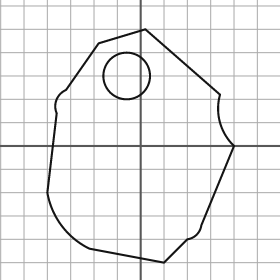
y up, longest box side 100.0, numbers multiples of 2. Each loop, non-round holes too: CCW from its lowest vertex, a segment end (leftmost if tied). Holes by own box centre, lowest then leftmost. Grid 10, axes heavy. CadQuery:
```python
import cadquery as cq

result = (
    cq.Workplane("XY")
    .moveTo(10.0, -50.0)
    .lineTo(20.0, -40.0)
    .threePointArc((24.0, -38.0), (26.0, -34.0))
    .lineTo(40.0, 0.0)
    .threePointArc((34.0, 10.0), (34.0, 22.0))
    .lineTo(2.0, 50.0)
    .lineTo(-18.0, 44.0)
    .lineTo(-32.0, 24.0)
    .threePointArc((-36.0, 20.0), (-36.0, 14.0))
    .lineTo(-40.0, -20.0)
    .threePointArc((-34.0, -34.0), (-22.0, -44.0))
    .close()
    .moveTo(-6.0, 30.0)
    .circle(10.0)
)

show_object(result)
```